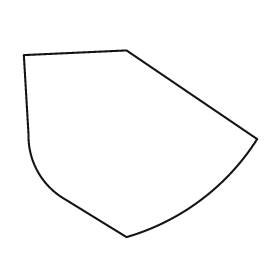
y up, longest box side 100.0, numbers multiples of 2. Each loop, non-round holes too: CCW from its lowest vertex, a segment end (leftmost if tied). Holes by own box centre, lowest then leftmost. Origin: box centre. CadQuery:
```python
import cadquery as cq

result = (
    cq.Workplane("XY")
    .moveTo(-6.0, -40.0)
    .threePointArc((26.0, -24.0), (50.0, 2.0))
    .lineTo(-6.0, 40.0)
    .lineTo(-50.0, 38.0)
    .lineTo(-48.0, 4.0)
    .threePointArc((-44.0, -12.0), (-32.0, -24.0))
    .close()
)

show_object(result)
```